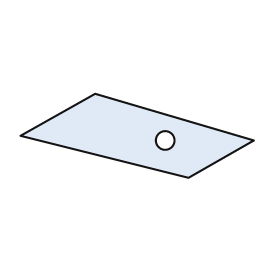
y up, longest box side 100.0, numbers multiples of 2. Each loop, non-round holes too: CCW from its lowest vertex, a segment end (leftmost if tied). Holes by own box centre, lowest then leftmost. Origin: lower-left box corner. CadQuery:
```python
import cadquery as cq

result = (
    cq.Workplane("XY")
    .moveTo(72.0, 0.0)
    .lineTo(100.0, 16.0)
    .lineTo(32.0, 36.0)
    .lineTo(0.0, 18.0)
    .close()
    .moveTo(62.0, 16.0)
    .circle(4.0)
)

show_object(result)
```